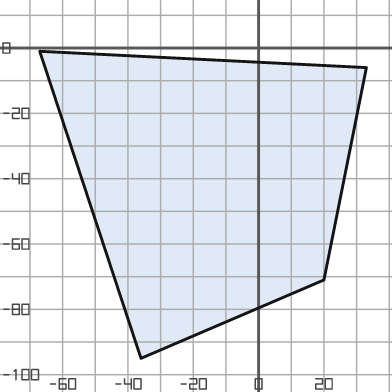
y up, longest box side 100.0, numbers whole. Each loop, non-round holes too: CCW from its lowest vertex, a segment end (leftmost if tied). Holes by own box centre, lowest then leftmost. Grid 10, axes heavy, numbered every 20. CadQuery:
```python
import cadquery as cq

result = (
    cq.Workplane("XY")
    .moveTo(-36.0, -95.0)
    .lineTo(20.0, -71.0)
    .lineTo(33.0, -6.0)
    .lineTo(-67.0, -1.0)
    .close()
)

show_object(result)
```